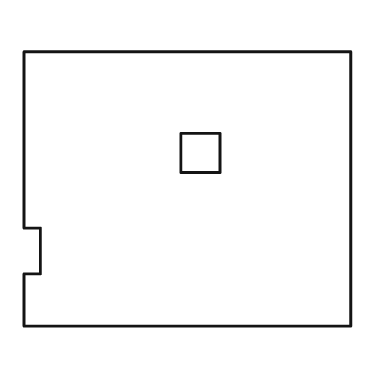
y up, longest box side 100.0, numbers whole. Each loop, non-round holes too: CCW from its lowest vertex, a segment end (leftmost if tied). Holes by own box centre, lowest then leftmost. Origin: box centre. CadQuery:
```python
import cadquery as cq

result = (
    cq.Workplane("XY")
    .moveTo(-50.0, -42.0)
    .lineTo(50.0, -42.0)
    .lineTo(50.0, 42.0)
    .lineTo(-50.0, 42.0)
    .lineTo(-50.0, -12.0)
    .lineTo(-45.0, -12.0)
    .lineTo(-45.0, -26.0)
    .lineTo(-50.0, -26.0)
    .close()
    .moveTo(-2.0, 5.0)
    .lineTo(10.0, 5.0)
    .lineTo(10.0, 17.0)
    .lineTo(-2.0, 17.0)
    .close()
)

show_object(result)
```